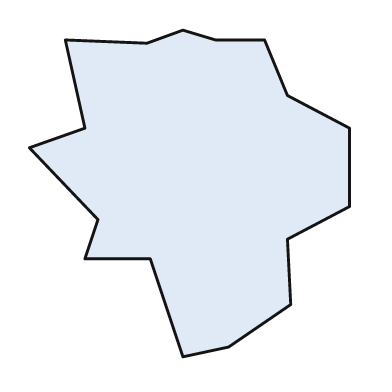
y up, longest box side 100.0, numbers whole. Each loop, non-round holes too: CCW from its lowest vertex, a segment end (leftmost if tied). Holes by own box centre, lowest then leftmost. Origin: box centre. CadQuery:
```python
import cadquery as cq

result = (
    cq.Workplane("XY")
    .moveTo(-2.0, -50.0)
    .lineTo(12.0, -47.0)
    .lineTo(31.0, -34.0)
    .lineTo(30.0, -14.0)
    .lineTo(49.0, -4.0)
    .lineTo(49.0, 20.0)
    .lineTo(30.0, 30.0)
    .lineTo(23.0, 47.0)
    .lineTo(8.0, 47.0)
    .lineTo(-2.0, 50.0)
    .lineTo(-13.0, 46.0)
    .lineTo(-38.0, 47.0)
    .lineTo(-32.0, 20.0)
    .lineTo(-49.0, 14.0)
    .lineTo(-28.0, -8.0)
    .lineTo(-32.0, -20.0)
    .lineTo(-12.0, -20.0)
    .close()
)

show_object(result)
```